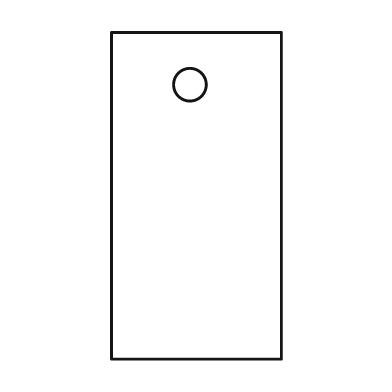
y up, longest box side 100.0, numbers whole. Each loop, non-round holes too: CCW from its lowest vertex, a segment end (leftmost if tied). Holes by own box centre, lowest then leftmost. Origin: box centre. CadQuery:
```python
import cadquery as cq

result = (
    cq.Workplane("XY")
    .moveTo(-26.0, -50.0)
    .lineTo(26.0, -50.0)
    .lineTo(26.0, 50.0)
    .lineTo(-26.0, 50.0)
    .close()
    .moveTo(-2.0, 34.0)
    .circle(5.0)
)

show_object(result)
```